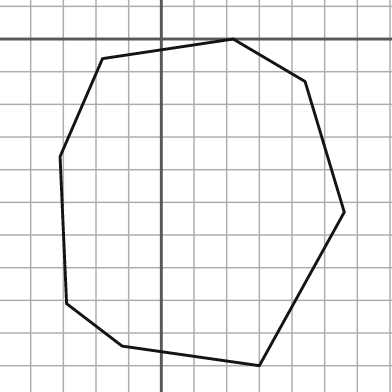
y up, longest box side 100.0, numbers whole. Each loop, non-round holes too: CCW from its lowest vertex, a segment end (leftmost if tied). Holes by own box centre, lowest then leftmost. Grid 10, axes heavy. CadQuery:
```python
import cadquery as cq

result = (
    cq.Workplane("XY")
    .moveTo(30.0, -100.0)
    .lineTo(56.0, -53.0)
    .lineTo(44.0, -13.0)
    .lineTo(22.0, 0.0)
    .lineTo(-18.0, -6.0)
    .lineTo(-31.0, -36.0)
    .lineTo(-29.0, -81.0)
    .lineTo(-12.0, -94.0)
    .close()
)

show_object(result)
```